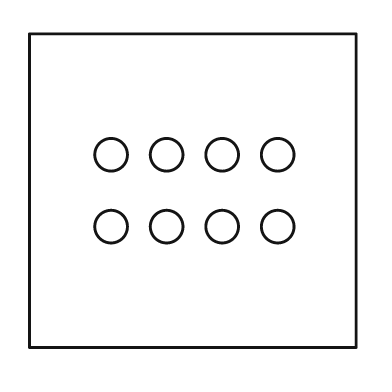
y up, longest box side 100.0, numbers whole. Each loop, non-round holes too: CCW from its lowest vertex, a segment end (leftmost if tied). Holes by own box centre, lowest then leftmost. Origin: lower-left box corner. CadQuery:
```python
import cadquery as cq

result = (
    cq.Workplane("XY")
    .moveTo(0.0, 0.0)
    .lineTo(100.0, 0.0)
    .lineTo(100.0, 96.0)
    .lineTo(0.0, 96.0)
    .close()
    .moveTo(25.0, 37.0)
    .circle(5.0)
    .moveTo(42.0, 37.0)
    .circle(5.0)
    .moveTo(59.0, 37.0)
    .circle(5.0)
    .moveTo(76.0, 37.0)
    .circle(5.0)
    .moveTo(25.0, 59.0)
    .circle(5.0)
    .moveTo(42.0, 59.0)
    .circle(5.0)
    .moveTo(59.0, 59.0)
    .circle(5.0)
    .moveTo(76.0, 59.0)
    .circle(5.0)
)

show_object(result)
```